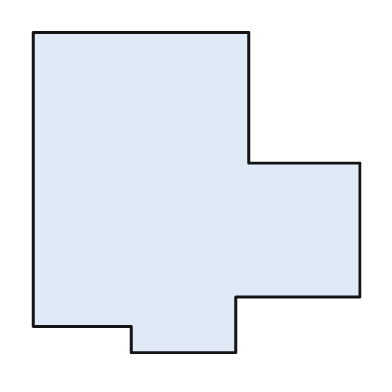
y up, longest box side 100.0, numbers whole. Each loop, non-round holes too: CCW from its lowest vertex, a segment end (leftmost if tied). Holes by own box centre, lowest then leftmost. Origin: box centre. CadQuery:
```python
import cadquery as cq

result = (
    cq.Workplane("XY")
    .moveTo(-20.0, -49.0)
    .lineTo(12.0, -49.0)
    .lineTo(12.0, -32.0)
    .lineTo(50.0, -32.0)
    .lineTo(50.0, 9.0)
    .lineTo(16.0, 9.0)
    .lineTo(16.0, 49.0)
    .lineTo(-50.0, 49.0)
    .lineTo(-50.0, -41.0)
    .lineTo(-20.0, -41.0)
    .close()
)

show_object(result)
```